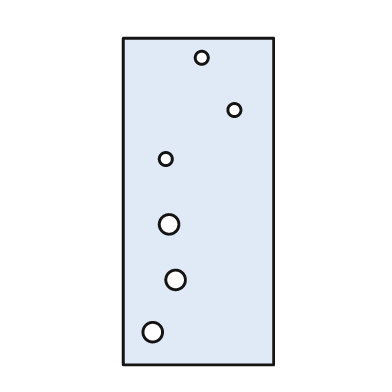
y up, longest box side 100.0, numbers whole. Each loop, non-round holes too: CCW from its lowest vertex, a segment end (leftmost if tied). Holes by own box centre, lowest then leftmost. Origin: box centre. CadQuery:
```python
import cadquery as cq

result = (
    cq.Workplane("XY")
    .moveTo(-23.0, -50.0)
    .lineTo(23.0, -50.0)
    .lineTo(23.0, 50.0)
    .lineTo(-23.0, 50.0)
    .close()
    .moveTo(-14.0, -40.0)
    .circle(3.0)
    .moveTo(-7.0, -24.0)
    .circle(3.0)
    .moveTo(-9.0, -7.0)
    .circle(3.0)
    .moveTo(-10.0, 13.0)
    .circle(2.0)
    .moveTo(11.0, 28.0)
    .circle(2.0)
    .moveTo(1.0, 44.0)
    .circle(2.0)
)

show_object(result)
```